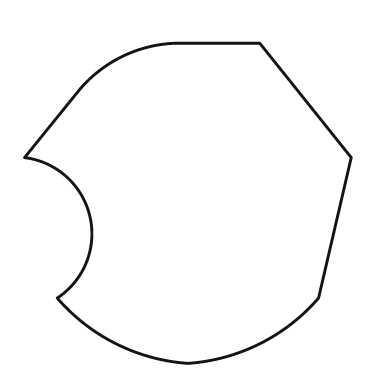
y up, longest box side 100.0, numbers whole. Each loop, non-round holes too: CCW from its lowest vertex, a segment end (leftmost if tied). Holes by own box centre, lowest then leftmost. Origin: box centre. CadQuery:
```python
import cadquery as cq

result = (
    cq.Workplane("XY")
    .moveTo(0.0, -49.0)
    .threePointArc((22.0, -43.0), (40.0, -29.0))
    .lineTo(50.0, 14.0)
    .lineTo(22.0, 49.0)
    .lineTo(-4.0, 49.0)
    .threePointArc((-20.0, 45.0), (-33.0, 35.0))
    .lineTo(-50.0, 14.0)
    .threePointArc((-30.0, -4.0), (-40.0, -29.0))
    .threePointArc((-22.0, -43.0), (0.0, -49.0))
    .close()
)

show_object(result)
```